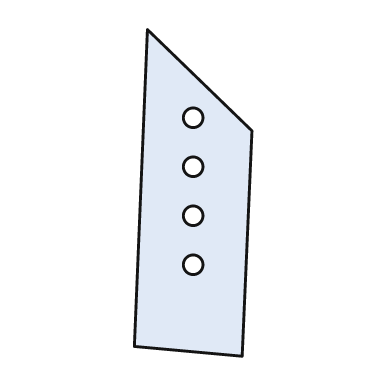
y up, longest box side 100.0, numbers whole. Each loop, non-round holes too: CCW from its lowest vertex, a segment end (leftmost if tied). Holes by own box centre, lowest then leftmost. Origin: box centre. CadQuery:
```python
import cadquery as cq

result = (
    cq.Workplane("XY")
    .moveTo(15.0, -50.0)
    .lineTo(18.0, 19.0)
    .lineTo(-14.0, 50.0)
    .lineTo(-18.0, -47.0)
    .close()
    .moveTo(0.0, -22.0)
    .circle(3.0)
    .moveTo(0.0, -7.0)
    .circle(3.0)
    .moveTo(0.0, 8.0)
    .circle(3.0)
    .moveTo(0.0, 23.0)
    .circle(3.0)
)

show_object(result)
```